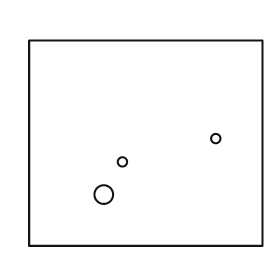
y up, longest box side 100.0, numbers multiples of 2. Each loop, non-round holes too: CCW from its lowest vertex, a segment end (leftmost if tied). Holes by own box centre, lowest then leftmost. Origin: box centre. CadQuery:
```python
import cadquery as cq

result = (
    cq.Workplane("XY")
    .moveTo(-50.0, -44.0)
    .lineTo(50.0, -44.0)
    .lineTo(50.0, 44.0)
    .lineTo(-50.0, 44.0)
    .close()
    .moveTo(-18.0, -22.0)
    .circle(4.0)
    .moveTo(-10.0, -8.0)
    .circle(2.0)
    .moveTo(30.0, 2.0)
    .circle(2.0)
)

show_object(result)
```